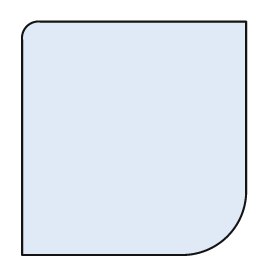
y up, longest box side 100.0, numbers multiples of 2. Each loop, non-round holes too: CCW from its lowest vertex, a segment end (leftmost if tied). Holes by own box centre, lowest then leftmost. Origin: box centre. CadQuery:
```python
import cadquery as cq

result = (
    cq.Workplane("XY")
    .moveTo(-48.0, -50.0)
    .lineTo(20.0, -50.0)
    .threePointArc((40.0, -42.0), (48.0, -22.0))
    .lineTo(48.0, 50.0)
    .lineTo(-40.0, 50.0)
    .threePointArc((-46.0, 48.0), (-48.0, 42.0))
    .close()
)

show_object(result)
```